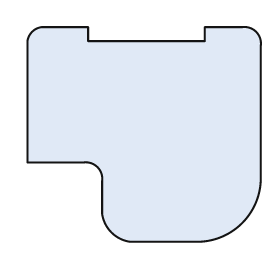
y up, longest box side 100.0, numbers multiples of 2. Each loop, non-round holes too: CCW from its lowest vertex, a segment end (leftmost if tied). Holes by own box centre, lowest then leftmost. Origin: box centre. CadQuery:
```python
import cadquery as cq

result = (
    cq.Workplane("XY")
    .moveTo(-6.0, -46.0)
    .lineTo(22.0, -46.0)
    .threePointArc((42.0, -38.0), (50.0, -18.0))
    .lineTo(50.0, 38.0)
    .threePointArc((48.0, 44.0), (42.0, 46.0))
    .lineTo(26.0, 46.0)
    .lineTo(26.0, 40.0)
    .lineTo(-24.0, 40.0)
    .lineTo(-24.0, 46.0)
    .lineTo(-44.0, 46.0)
    .threePointArc((-48.0, 44.0), (-50.0, 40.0))
    .lineTo(-50.0, -12.0)
    .lineTo(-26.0, -12.0)
    .threePointArc((-20.0, -14.0), (-18.0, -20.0))
    .lineTo(-18.0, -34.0)
    .threePointArc((-14.0, -42.0), (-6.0, -46.0))
    .close()
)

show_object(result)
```